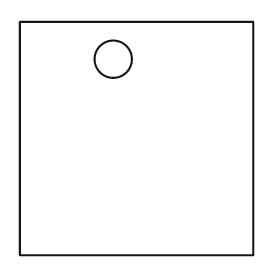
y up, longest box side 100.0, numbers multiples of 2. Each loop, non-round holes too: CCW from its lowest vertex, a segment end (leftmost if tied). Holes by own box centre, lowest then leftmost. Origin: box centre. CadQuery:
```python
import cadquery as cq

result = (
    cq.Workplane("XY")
    .moveTo(-50.0, -50.0)
    .lineTo(50.0, -50.0)
    .lineTo(50.0, 50.0)
    .lineTo(-50.0, 50.0)
    .close()
    .moveTo(-10.0, 34.0)
    .circle(8.0)
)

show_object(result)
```